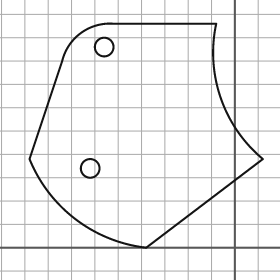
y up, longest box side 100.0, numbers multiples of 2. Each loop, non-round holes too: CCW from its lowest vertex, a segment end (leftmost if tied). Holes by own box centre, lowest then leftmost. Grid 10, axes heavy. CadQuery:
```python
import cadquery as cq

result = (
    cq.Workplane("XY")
    .moveTo(-38.0, 0.0)
    .lineTo(12.0, 38.0)
    .threePointArc((-6.0, 64.0), (-8.0, 96.0))
    .lineTo(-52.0, 96.0)
    .threePointArc((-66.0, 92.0), (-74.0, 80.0))
    .lineTo(-88.0, 38.0)
    .threePointArc((-68.0, 12.0), (-38.0, 0.0))
    .close()
    .moveTo(-62.0, 34.0)
    .circle(4.0)
    .moveTo(-56.0, 86.0)
    .circle(4.0)
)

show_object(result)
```